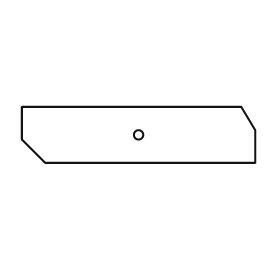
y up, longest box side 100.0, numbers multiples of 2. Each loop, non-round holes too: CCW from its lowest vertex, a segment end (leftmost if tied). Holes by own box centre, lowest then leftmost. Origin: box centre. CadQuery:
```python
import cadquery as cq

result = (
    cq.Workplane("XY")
    .moveTo(-40.0, -12.0)
    .lineTo(50.0, -12.0)
    .lineTo(50.0, 2.0)
    .lineTo(44.0, 12.0)
    .lineTo(-50.0, 12.0)
    .lineTo(-50.0, -2.0)
    .close()
    .moveTo(0.0, 0.0)
    .circle(2.0)
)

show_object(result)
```